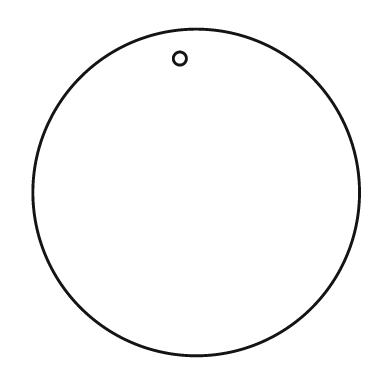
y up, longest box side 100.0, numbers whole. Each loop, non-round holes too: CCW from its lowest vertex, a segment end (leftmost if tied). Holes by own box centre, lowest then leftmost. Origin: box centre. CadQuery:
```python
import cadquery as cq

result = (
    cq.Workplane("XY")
    .moveTo(0.0, 0.0)
    .circle(50.0)
    .moveTo(-5.0, 41.0)
    .circle(2.0)
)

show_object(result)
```